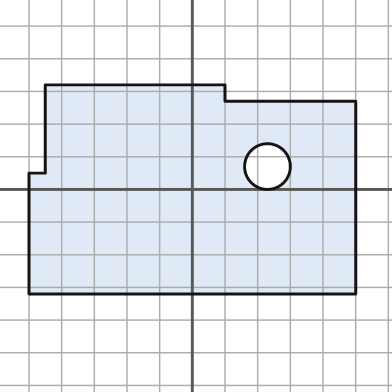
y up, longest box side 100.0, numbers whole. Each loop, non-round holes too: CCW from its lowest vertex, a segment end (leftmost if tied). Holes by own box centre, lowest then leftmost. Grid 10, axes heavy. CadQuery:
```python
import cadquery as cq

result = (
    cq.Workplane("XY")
    .moveTo(-50.0, -32.0)
    .lineTo(50.0, -32.0)
    .lineTo(50.0, 27.0)
    .lineTo(10.0, 27.0)
    .lineTo(10.0, 32.0)
    .lineTo(-45.0, 32.0)
    .lineTo(-45.0, 5.0)
    .lineTo(-50.0, 5.0)
    .close()
    .moveTo(23.0, 7.0)
    .circle(7.0)
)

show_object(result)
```